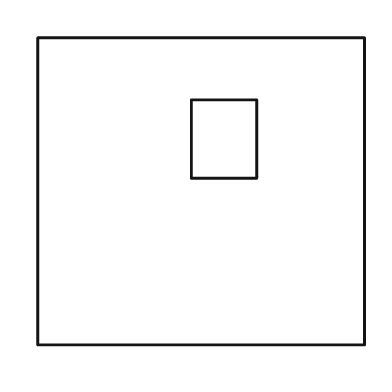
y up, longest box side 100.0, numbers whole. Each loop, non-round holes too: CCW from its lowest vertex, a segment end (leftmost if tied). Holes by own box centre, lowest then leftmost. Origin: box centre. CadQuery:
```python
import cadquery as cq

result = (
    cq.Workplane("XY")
    .moveTo(-50.0, -47.0)
    .lineTo(50.0, -47.0)
    .lineTo(50.0, 47.0)
    .lineTo(-50.0, 47.0)
    .close()
    .moveTo(-3.0, 4.0)
    .lineTo(17.0, 4.0)
    .lineTo(17.0, 28.0)
    .lineTo(-3.0, 28.0)
    .close()
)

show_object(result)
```